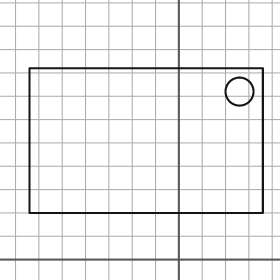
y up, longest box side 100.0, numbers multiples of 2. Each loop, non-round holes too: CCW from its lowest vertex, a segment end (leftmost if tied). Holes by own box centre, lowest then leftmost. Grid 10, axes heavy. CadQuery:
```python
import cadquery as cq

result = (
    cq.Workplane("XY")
    .moveTo(-64.0, 20.0)
    .lineTo(36.0, 20.0)
    .lineTo(36.0, 82.0)
    .lineTo(-64.0, 82.0)
    .close()
    .moveTo(26.0, 72.0)
    .circle(6.0)
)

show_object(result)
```